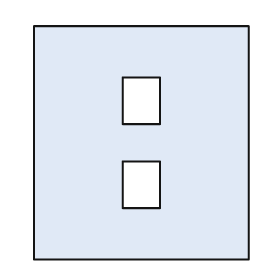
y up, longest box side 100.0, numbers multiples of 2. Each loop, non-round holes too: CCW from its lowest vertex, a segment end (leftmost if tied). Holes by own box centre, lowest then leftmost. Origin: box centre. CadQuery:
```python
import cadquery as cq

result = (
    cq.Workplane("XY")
    .moveTo(-46.0, -50.0)
    .lineTo(46.0, -50.0)
    .lineTo(46.0, 50.0)
    .lineTo(-46.0, 50.0)
    .close()
    .moveTo(-8.0, -28.0)
    .lineTo(8.0, -28.0)
    .lineTo(8.0, -8.0)
    .lineTo(-8.0, -8.0)
    .close()
    .moveTo(-8.0, 8.0)
    .lineTo(8.0, 8.0)
    .lineTo(8.0, 28.0)
    .lineTo(-8.0, 28.0)
    .close()
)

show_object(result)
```